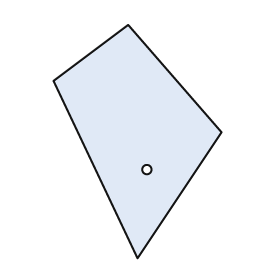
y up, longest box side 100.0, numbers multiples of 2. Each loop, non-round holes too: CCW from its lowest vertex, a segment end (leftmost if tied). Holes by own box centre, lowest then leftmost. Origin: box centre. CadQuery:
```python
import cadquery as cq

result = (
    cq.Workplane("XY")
    .moveTo(0.0, -50.0)
    .lineTo(36.0, 4.0)
    .lineTo(-4.0, 50.0)
    .lineTo(-36.0, 26.0)
    .close()
    .moveTo(4.0, -12.0)
    .circle(2.0)
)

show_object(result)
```